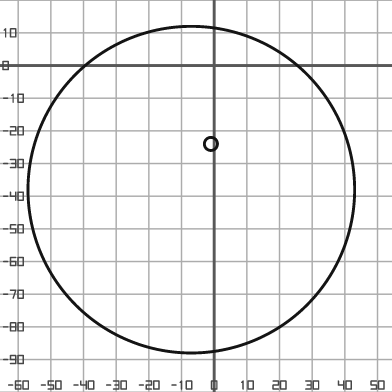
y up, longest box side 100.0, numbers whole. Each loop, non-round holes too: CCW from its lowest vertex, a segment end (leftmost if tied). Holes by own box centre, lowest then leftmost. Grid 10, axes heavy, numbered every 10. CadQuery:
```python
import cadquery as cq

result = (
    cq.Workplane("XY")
    .moveTo(-7.0, -38.0)
    .circle(50.0)
    .moveTo(-1.0, -24.0)
    .circle(2.0)
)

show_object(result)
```